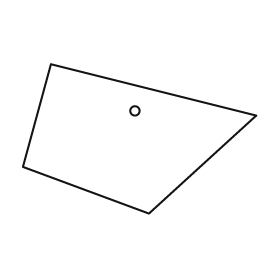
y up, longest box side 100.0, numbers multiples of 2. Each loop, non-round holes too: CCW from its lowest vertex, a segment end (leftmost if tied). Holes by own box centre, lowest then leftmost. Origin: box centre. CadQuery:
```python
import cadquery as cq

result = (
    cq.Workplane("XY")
    .moveTo(4.0, -32.0)
    .lineTo(50.0, 10.0)
    .lineTo(-38.0, 32.0)
    .lineTo(-50.0, -12.0)
    .close()
    .moveTo(-2.0, 12.0)
    .circle(2.0)
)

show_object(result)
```